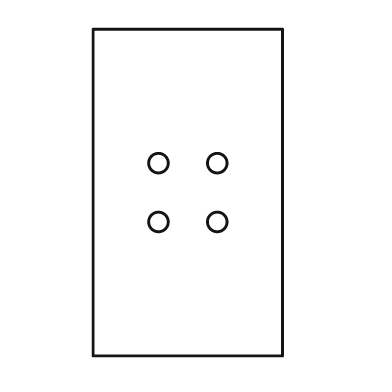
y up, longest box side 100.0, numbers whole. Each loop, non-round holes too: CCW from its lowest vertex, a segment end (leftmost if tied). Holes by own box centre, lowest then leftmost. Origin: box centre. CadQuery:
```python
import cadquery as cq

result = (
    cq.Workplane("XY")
    .moveTo(-29.0, -50.0)
    .lineTo(29.0, -50.0)
    .lineTo(29.0, 50.0)
    .lineTo(-29.0, 50.0)
    .close()
    .moveTo(-9.0, -9.0)
    .circle(3.0)
    .moveTo(9.0, -9.0)
    .circle(3.0)
    .moveTo(-9.0, 9.0)
    .circle(3.0)
    .moveTo(9.0, 9.0)
    .circle(3.0)
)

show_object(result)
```